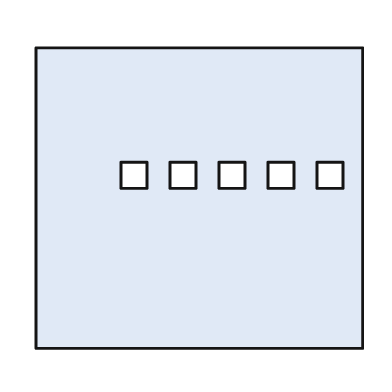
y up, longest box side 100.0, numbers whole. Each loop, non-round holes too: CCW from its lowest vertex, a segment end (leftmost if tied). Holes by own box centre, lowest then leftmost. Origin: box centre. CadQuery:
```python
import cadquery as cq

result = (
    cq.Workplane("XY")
    .moveTo(-50.0, -46.0)
    .lineTo(50.0, -46.0)
    .lineTo(50.0, 46.0)
    .lineTo(-50.0, 46.0)
    .close()
    .moveTo(-24.0, 3.0)
    .lineTo(-16.0, 3.0)
    .lineTo(-16.0, 11.0)
    .lineTo(-24.0, 11.0)
    .close()
    .moveTo(-9.0, 3.0)
    .lineTo(-1.0, 3.0)
    .lineTo(-1.0, 11.0)
    .lineTo(-9.0, 11.0)
    .close()
    .moveTo(6.0, 3.0)
    .lineTo(14.0, 3.0)
    .lineTo(14.0, 11.0)
    .lineTo(6.0, 11.0)
    .close()
    .moveTo(21.0, 3.0)
    .lineTo(29.0, 3.0)
    .lineTo(29.0, 11.0)
    .lineTo(21.0, 11.0)
    .close()
    .moveTo(36.0, 3.0)
    .lineTo(44.0, 3.0)
    .lineTo(44.0, 11.0)
    .lineTo(36.0, 11.0)
    .close()
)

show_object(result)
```